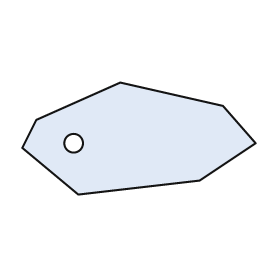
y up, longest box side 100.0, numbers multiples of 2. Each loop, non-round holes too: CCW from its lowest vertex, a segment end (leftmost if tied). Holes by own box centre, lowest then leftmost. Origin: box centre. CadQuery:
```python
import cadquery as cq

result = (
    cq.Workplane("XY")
    .moveTo(-26.0, -24.0)
    .lineTo(26.0, -18.0)
    .lineTo(50.0, -2.0)
    .lineTo(36.0, 14.0)
    .lineTo(-8.0, 24.0)
    .lineTo(-44.0, 8.0)
    .lineTo(-50.0, -4.0)
    .close()
    .moveTo(-28.0, -2.0)
    .circle(4.0)
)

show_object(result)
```